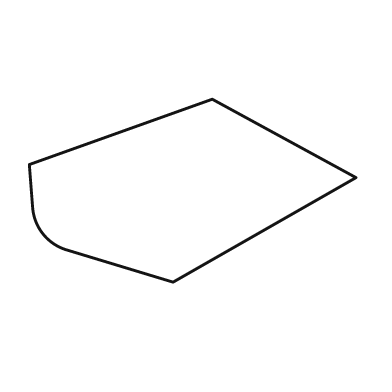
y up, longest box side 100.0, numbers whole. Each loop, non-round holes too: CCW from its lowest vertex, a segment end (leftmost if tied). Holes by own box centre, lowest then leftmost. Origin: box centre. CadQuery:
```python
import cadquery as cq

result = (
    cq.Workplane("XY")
    .moveTo(-6.0, -28.0)
    .lineTo(50.0, 4.0)
    .lineTo(6.0, 28.0)
    .lineTo(-50.0, 8.0)
    .lineTo(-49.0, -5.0)
    .threePointArc((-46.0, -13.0), (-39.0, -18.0))
    .close()
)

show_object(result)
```